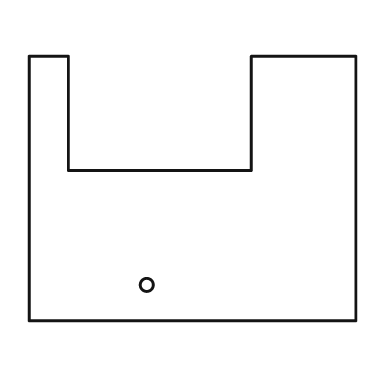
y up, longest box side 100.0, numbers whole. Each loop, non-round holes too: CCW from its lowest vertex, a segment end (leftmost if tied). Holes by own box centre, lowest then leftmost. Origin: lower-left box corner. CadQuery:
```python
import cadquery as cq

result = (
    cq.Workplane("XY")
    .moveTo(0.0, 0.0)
    .lineTo(100.0, 0.0)
    .lineTo(100.0, 81.0)
    .lineTo(68.0, 81.0)
    .lineTo(68.0, 46.0)
    .lineTo(12.0, 46.0)
    .lineTo(12.0, 81.0)
    .lineTo(0.0, 81.0)
    .close()
    .moveTo(36.0, 11.0)
    .circle(2.0)
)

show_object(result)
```